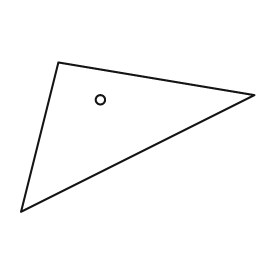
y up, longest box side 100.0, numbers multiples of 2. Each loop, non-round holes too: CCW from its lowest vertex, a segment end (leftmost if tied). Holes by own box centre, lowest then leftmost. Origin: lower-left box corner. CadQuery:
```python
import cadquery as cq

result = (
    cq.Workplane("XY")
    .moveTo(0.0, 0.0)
    .lineTo(100.0, 50.0)
    .lineTo(16.0, 64.0)
    .close()
    .moveTo(34.0, 48.0)
    .circle(2.0)
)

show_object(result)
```